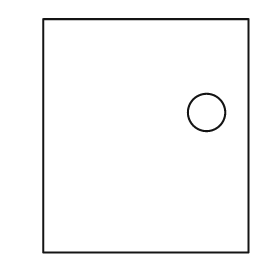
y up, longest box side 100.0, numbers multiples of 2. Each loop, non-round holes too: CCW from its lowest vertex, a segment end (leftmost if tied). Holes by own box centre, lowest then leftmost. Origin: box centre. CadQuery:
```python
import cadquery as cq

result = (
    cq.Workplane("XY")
    .moveTo(-44.0, -50.0)
    .lineTo(44.0, -50.0)
    .lineTo(44.0, 50.0)
    .lineTo(-44.0, 50.0)
    .close()
    .moveTo(26.0, 10.0)
    .circle(8.0)
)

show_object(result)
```